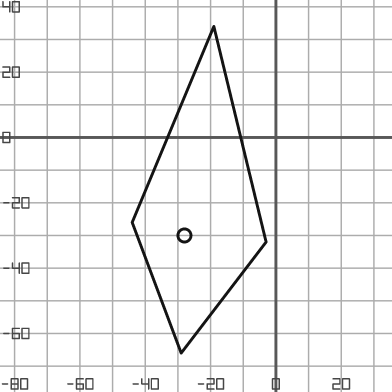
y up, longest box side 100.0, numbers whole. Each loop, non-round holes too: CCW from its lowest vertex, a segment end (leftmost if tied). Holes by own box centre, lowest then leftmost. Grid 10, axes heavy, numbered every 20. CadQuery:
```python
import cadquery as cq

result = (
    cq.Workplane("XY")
    .moveTo(-29.0, -66.0)
    .lineTo(-3.0, -32.0)
    .lineTo(-19.0, 34.0)
    .lineTo(-44.0, -26.0)
    .close()
    .moveTo(-28.0, -30.0)
    .circle(2.0)
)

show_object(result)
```